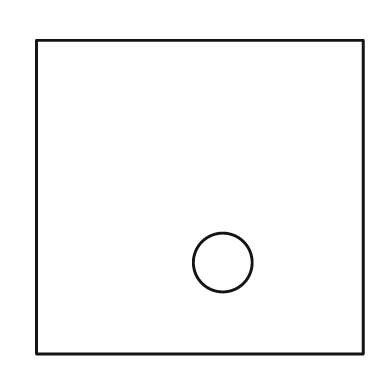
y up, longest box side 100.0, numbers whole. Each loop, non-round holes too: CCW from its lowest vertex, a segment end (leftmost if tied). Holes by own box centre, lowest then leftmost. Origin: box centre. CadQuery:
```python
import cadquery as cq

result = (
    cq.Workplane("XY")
    .moveTo(-50.0, -48.0)
    .lineTo(50.0, -48.0)
    .lineTo(50.0, 48.0)
    .lineTo(-50.0, 48.0)
    .close()
    .moveTo(7.0, -20.0)
    .circle(9.0)
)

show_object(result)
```